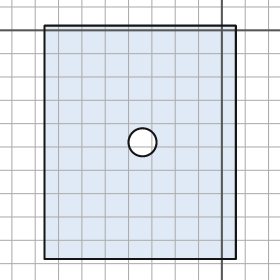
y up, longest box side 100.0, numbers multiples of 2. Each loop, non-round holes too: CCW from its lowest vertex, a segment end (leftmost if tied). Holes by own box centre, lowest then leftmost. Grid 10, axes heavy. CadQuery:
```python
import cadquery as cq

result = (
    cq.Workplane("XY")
    .moveTo(-76.0, -98.0)
    .lineTo(6.0, -98.0)
    .lineTo(6.0, 2.0)
    .lineTo(-76.0, 2.0)
    .close()
    .moveTo(-34.0, -48.0)
    .circle(6.0)
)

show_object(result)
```